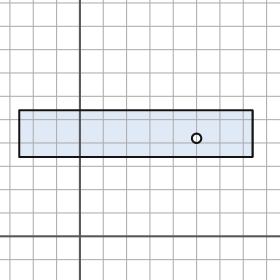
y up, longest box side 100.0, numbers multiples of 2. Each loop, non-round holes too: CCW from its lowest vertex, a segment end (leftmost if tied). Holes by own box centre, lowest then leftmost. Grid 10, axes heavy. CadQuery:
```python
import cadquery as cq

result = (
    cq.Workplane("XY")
    .moveTo(-26.0, 34.0)
    .lineTo(74.0, 34.0)
    .lineTo(74.0, 54.0)
    .lineTo(-26.0, 54.0)
    .close()
    .moveTo(50.0, 42.0)
    .circle(2.0)
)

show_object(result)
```